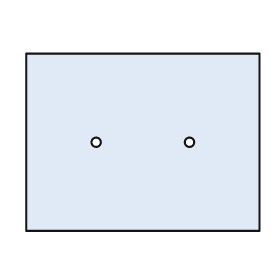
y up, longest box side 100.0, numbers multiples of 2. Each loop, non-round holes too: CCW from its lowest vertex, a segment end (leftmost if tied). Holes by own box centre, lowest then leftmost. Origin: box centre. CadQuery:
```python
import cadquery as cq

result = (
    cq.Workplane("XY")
    .moveTo(-50.0, -38.0)
    .lineTo(50.0, -38.0)
    .lineTo(50.0, 38.0)
    .lineTo(-50.0, 38.0)
    .close()
    .moveTo(-20.0, 0.0)
    .circle(2.0)
    .moveTo(20.0, 0.0)
    .circle(2.0)
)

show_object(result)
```